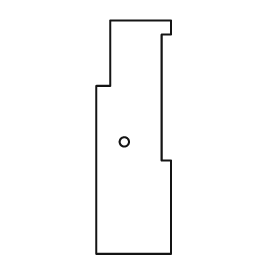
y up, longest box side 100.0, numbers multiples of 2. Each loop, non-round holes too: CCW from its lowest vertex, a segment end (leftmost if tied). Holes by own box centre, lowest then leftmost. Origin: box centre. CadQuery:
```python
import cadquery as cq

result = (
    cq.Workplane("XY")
    .moveTo(-16.0, -50.0)
    .lineTo(16.0, -50.0)
    .lineTo(16.0, -10.0)
    .lineTo(12.0, -10.0)
    .lineTo(12.0, 44.0)
    .lineTo(16.0, 44.0)
    .lineTo(16.0, 50.0)
    .lineTo(-10.0, 50.0)
    .lineTo(-10.0, 22.0)
    .lineTo(-16.0, 22.0)
    .close()
    .moveTo(-4.0, -2.0)
    .circle(2.0)
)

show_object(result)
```